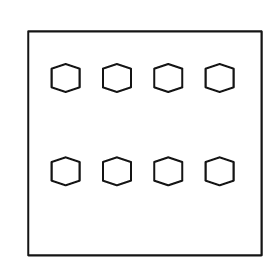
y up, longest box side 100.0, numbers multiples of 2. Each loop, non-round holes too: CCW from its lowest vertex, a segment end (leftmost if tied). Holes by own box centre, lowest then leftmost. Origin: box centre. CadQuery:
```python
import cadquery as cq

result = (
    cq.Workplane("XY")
    .moveTo(-50.0, -48.0)
    .lineTo(50.0, -48.0)
    .lineTo(50.0, 48.0)
    .lineTo(-50.0, 48.0)
    .close()
    .moveTo(-34.0, -18.0)
    .lineTo(-28.0, -16.0)
    .lineTo(-28.0, -8.0)
    .lineTo(-34.0, -6.0)
    .lineTo(-40.0, -8.0)
    .lineTo(-40.0, -16.0)
    .close()
    .moveTo(-12.0, -18.0)
    .lineTo(-6.0, -16.0)
    .lineTo(-6.0, -8.0)
    .lineTo(-12.0, -6.0)
    .lineTo(-18.0, -8.0)
    .lineTo(-18.0, -16.0)
    .close()
    .moveTo(10.0, -18.0)
    .lineTo(16.0, -16.0)
    .lineTo(16.0, -8.0)
    .lineTo(10.0, -6.0)
    .lineTo(4.0, -8.0)
    .lineTo(4.0, -16.0)
    .close()
    .moveTo(32.0, -18.0)
    .lineTo(38.0, -16.0)
    .lineTo(38.0, -8.0)
    .lineTo(32.0, -6.0)
    .lineTo(26.0, -8.0)
    .lineTo(26.0, -16.0)
    .close()
    .moveTo(-34.0, 22.0)
    .lineTo(-28.0, 24.0)
    .lineTo(-28.0, 32.0)
    .lineTo(-34.0, 34.0)
    .lineTo(-40.0, 32.0)
    .lineTo(-40.0, 24.0)
    .close()
    .moveTo(-12.0, 22.0)
    .lineTo(-6.0, 24.0)
    .lineTo(-6.0, 32.0)
    .lineTo(-12.0, 34.0)
    .lineTo(-18.0, 32.0)
    .lineTo(-18.0, 24.0)
    .close()
    .moveTo(10.0, 22.0)
    .lineTo(16.0, 24.0)
    .lineTo(16.0, 32.0)
    .lineTo(10.0, 34.0)
    .lineTo(4.0, 32.0)
    .lineTo(4.0, 24.0)
    .close()
    .moveTo(32.0, 22.0)
    .lineTo(38.0, 24.0)
    .lineTo(38.0, 32.0)
    .lineTo(32.0, 34.0)
    .lineTo(26.0, 32.0)
    .lineTo(26.0, 24.0)
    .close()
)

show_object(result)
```